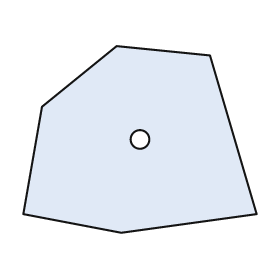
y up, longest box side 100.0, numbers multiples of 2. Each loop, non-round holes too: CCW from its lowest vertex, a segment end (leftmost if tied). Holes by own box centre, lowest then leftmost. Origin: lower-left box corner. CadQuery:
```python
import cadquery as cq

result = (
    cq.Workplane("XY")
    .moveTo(42.0, 0.0)
    .lineTo(100.0, 8.0)
    .lineTo(80.0, 76.0)
    .lineTo(40.0, 80.0)
    .lineTo(8.0, 54.0)
    .lineTo(0.0, 8.0)
    .close()
    .moveTo(50.0, 40.0)
    .circle(4.0)
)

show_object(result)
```